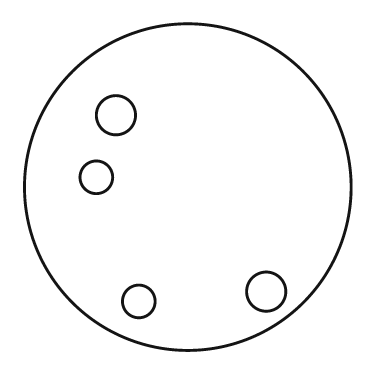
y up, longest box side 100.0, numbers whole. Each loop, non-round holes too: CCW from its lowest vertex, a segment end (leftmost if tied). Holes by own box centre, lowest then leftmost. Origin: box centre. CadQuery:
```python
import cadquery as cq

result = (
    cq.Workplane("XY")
    .moveTo(0.0, 0.0)
    .circle(50.0)
    .moveTo(-15.0, -35.0)
    .circle(5.0)
    .moveTo(24.0, -32.0)
    .circle(6.0)
    .moveTo(-28.0, 3.0)
    .circle(5.0)
    .moveTo(-22.0, 22.0)
    .circle(6.0)
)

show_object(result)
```